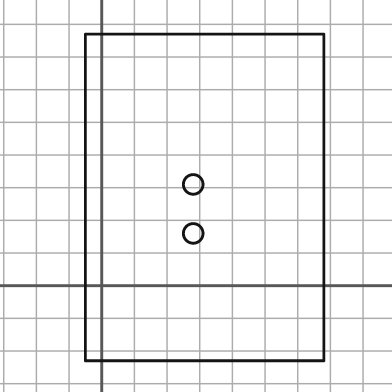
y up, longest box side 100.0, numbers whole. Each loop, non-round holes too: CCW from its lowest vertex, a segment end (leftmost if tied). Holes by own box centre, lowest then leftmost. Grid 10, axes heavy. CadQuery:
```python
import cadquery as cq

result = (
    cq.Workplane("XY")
    .moveTo(-5.0, -23.0)
    .lineTo(68.0, -23.0)
    .lineTo(68.0, 77.0)
    .lineTo(-5.0, 77.0)
    .close()
    .moveTo(28.0, 16.0)
    .circle(3.0)
    .moveTo(28.0, 31.0)
    .circle(3.0)
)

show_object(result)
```